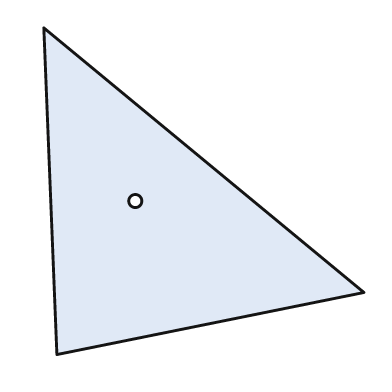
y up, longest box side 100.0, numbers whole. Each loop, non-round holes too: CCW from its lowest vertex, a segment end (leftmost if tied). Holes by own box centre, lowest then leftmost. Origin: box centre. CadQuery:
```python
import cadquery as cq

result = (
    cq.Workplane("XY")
    .moveTo(-45.0, -50.0)
    .lineTo(49.0, -31.0)
    .lineTo(-49.0, 50.0)
    .close()
    .moveTo(-21.0, -3.0)
    .circle(2.0)
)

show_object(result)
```